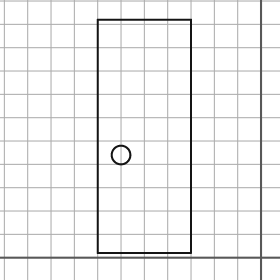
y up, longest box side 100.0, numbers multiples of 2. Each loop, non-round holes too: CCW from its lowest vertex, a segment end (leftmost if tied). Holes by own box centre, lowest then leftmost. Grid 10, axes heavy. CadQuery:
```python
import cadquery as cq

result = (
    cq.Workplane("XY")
    .moveTo(-70.0, 2.0)
    .lineTo(-30.0, 2.0)
    .lineTo(-30.0, 102.0)
    .lineTo(-70.0, 102.0)
    .close()
    .moveTo(-60.0, 44.0)
    .circle(4.0)
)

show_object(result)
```